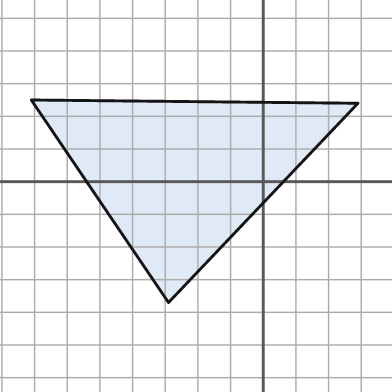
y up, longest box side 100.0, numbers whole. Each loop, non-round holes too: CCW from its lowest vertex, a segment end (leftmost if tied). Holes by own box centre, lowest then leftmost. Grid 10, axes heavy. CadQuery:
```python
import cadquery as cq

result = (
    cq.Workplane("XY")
    .moveTo(-29.0, -37.0)
    .lineTo(29.0, 24.0)
    .lineTo(-71.0, 25.0)
    .close()
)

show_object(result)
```